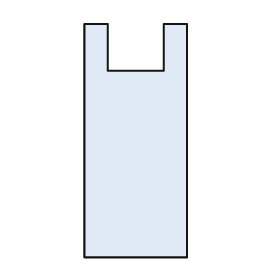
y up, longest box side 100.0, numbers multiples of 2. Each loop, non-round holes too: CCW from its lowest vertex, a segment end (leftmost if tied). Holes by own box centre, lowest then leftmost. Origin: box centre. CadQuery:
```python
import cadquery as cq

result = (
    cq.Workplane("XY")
    .moveTo(-22.0, -50.0)
    .lineTo(22.0, -50.0)
    .lineTo(22.0, 50.0)
    .lineTo(12.0, 50.0)
    .lineTo(12.0, 30.0)
    .lineTo(-12.0, 30.0)
    .lineTo(-12.0, 50.0)
    .lineTo(-22.0, 50.0)
    .close()
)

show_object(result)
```